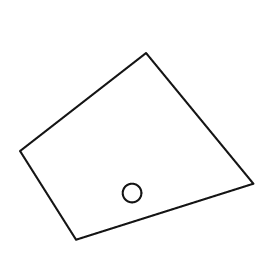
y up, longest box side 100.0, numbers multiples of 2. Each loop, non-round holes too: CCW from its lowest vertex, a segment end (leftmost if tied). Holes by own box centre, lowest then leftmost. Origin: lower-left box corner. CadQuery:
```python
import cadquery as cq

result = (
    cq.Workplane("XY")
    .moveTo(24.0, 0.0)
    .lineTo(100.0, 24.0)
    .lineTo(54.0, 80.0)
    .lineTo(0.0, 38.0)
    .close()
    .moveTo(48.0, 20.0)
    .circle(4.0)
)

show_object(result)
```